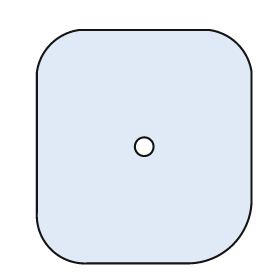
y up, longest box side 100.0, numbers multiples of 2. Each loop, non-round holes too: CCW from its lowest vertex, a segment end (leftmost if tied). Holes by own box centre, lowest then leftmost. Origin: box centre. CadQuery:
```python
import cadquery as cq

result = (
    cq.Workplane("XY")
    .moveTo(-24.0, -50.0)
    .lineTo(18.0, -50.0)
    .threePointArc((38.0, -42.0), (46.0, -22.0))
    .lineTo(46.0, 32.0)
    .threePointArc((40.0, 44.0), (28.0, 50.0))
    .lineTo(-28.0, 50.0)
    .threePointArc((-40.0, 44.0), (-46.0, 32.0))
    .lineTo(-46.0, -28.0)
    .threePointArc((-40.0, -44.0), (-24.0, -50.0))
    .close()
    .moveTo(0.0, 0.0)
    .circle(4.0)
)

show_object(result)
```